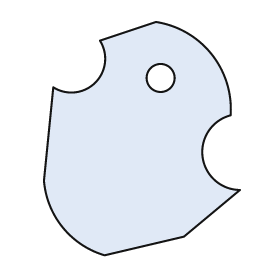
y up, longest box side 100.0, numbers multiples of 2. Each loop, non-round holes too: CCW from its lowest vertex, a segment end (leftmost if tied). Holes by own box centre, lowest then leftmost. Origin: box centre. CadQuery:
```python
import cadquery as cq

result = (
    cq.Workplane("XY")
    .moveTo(-16.0, -50.0)
    .lineTo(18.0, -42.0)
    .lineTo(42.0, -22.0)
    .threePointArc((26.0, -8.0), (38.0, 10.0))
    .threePointArc((30.0, 36.0), (6.0, 50.0))
    .lineTo(-18.0, 42.0)
    .threePointArc((-20.0, 24.0), (-38.0, 22.0))
    .lineTo(-42.0, -18.0)
    .threePointArc((-34.0, -38.0), (-16.0, -50.0))
    .close()
    .moveTo(8.0, 26.0)
    .circle(6.0)
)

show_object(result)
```